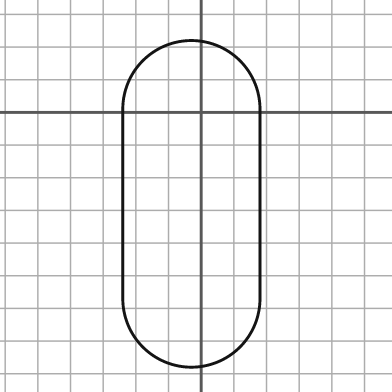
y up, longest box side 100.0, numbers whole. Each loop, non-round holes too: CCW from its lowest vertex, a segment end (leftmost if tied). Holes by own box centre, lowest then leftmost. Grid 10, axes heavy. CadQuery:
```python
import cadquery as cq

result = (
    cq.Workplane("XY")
    .moveTo(-24.0, -57.0)
    .threePointArc((-3.0, -78.0), (18.0, -57.0))
    .lineTo(18.0, 1.0)
    .threePointArc((-3.0, 22.0), (-24.0, 1.0))
    .close()
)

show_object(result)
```